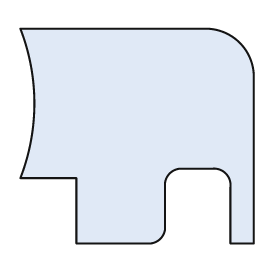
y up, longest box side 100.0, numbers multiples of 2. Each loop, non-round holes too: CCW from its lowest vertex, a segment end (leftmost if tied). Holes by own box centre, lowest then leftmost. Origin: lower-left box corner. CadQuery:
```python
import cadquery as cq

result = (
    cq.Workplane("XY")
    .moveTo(24.0, 0.0)
    .lineTo(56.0, 0.0)
    .threePointArc((60.0, 2.0), (62.0, 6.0))
    .lineTo(62.0, 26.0)
    .threePointArc((64.0, 30.0), (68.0, 32.0))
    .lineTo(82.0, 32.0)
    .threePointArc((88.0, 30.0), (90.0, 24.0))
    .lineTo(90.0, 0.0)
    .lineTo(100.0, 0.0)
    .lineTo(100.0, 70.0)
    .threePointArc((94.0, 86.0), (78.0, 92.0))
    .lineTo(0.0, 92.0)
    .threePointArc((6.0, 60.0), (0.0, 28.0))
    .lineTo(24.0, 28.0)
    .close()
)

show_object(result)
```